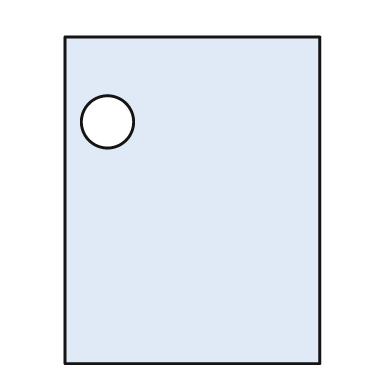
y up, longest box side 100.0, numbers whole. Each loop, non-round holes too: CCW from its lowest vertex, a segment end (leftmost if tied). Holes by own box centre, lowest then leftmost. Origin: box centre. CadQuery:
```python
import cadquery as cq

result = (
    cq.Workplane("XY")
    .moveTo(-39.0, -50.0)
    .lineTo(39.0, -50.0)
    .lineTo(39.0, 50.0)
    .lineTo(-39.0, 50.0)
    .close()
    .moveTo(-26.0, 24.0)
    .circle(8.0)
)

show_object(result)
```